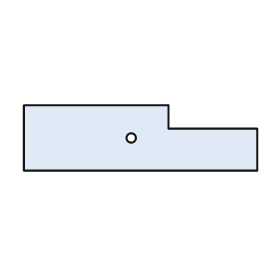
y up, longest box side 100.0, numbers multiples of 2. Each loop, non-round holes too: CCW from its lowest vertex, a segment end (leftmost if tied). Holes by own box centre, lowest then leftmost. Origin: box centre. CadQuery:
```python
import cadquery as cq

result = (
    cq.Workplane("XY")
    .moveTo(-50.0, -14.0)
    .lineTo(50.0, -14.0)
    .lineTo(50.0, 4.0)
    .lineTo(12.0, 4.0)
    .lineTo(12.0, 14.0)
    .lineTo(-50.0, 14.0)
    .close()
    .moveTo(-4.0, 0.0)
    .circle(2.0)
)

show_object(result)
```